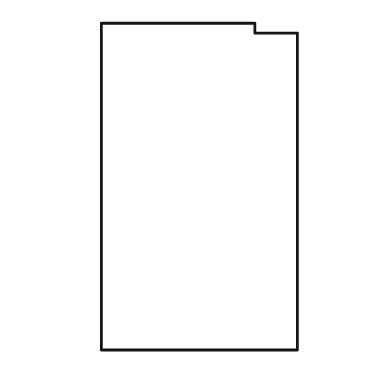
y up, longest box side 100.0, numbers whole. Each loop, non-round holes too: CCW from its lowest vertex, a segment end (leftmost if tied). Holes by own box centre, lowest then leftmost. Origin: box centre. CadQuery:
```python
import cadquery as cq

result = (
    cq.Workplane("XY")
    .moveTo(-30.0, -50.0)
    .lineTo(30.0, -50.0)
    .lineTo(30.0, 47.0)
    .lineTo(17.0, 47.0)
    .lineTo(17.0, 50.0)
    .lineTo(-30.0, 50.0)
    .close()
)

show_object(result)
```